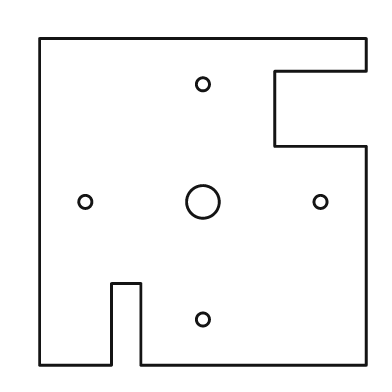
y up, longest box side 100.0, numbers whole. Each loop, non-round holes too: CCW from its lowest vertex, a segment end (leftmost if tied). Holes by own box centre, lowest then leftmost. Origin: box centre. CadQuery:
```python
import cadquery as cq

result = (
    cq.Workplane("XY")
    .moveTo(-50.0, -50.0)
    .lineTo(-28.0, -50.0)
    .lineTo(-28.0, -25.0)
    .lineTo(-19.0, -25.0)
    .lineTo(-19.0, -50.0)
    .lineTo(50.0, -50.0)
    .lineTo(50.0, 17.0)
    .lineTo(22.0, 17.0)
    .lineTo(22.0, 40.0)
    .lineTo(50.0, 40.0)
    .lineTo(50.0, 50.0)
    .lineTo(-50.0, 50.0)
    .close()
    .moveTo(0.0, -36.0)
    .circle(2.0)
    .moveTo(-36.0, 0.0)
    .circle(2.0)
    .moveTo(0.0, 0.0)
    .circle(5.0)
    .moveTo(36.0, 0.0)
    .circle(2.0)
    .moveTo(0.0, 36.0)
    .circle(2.0)
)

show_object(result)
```